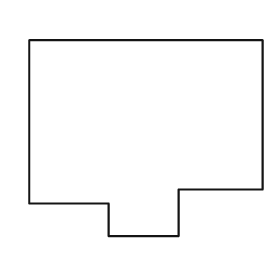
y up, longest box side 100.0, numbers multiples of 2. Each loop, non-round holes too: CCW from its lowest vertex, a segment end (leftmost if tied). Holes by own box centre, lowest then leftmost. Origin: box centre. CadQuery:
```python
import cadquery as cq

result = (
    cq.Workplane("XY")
    .moveTo(-16.0, -42.0)
    .lineTo(14.0, -42.0)
    .lineTo(14.0, -22.0)
    .lineTo(50.0, -22.0)
    .lineTo(50.0, 42.0)
    .lineTo(-50.0, 42.0)
    .lineTo(-50.0, -28.0)
    .lineTo(-16.0, -28.0)
    .close()
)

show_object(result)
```